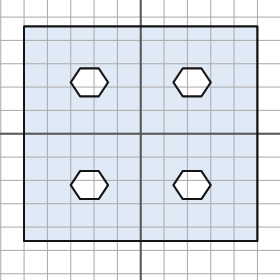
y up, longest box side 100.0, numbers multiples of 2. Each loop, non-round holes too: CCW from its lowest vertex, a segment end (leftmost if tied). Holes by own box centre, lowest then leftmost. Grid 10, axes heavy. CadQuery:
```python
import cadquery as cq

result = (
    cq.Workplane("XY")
    .moveTo(-50.0, -46.0)
    .lineTo(50.0, -46.0)
    .lineTo(50.0, 46.0)
    .lineTo(-50.0, 46.0)
    .close()
    .moveTo(-26.0, -28.0)
    .lineTo(-18.0, -28.0)
    .lineTo(-14.0, -22.0)
    .lineTo(-18.0, -16.0)
    .lineTo(-26.0, -16.0)
    .lineTo(-30.0, -22.0)
    .close()
    .moveTo(18.0, -28.0)
    .lineTo(26.0, -28.0)
    .lineTo(30.0, -22.0)
    .lineTo(26.0, -16.0)
    .lineTo(18.0, -16.0)
    .lineTo(14.0, -22.0)
    .close()
    .moveTo(-26.0, 16.0)
    .lineTo(-18.0, 16.0)
    .lineTo(-14.0, 22.0)
    .lineTo(-18.0, 28.0)
    .lineTo(-26.0, 28.0)
    .lineTo(-30.0, 22.0)
    .close()
    .moveTo(18.0, 16.0)
    .lineTo(26.0, 16.0)
    .lineTo(30.0, 22.0)
    .lineTo(26.0, 28.0)
    .lineTo(18.0, 28.0)
    .lineTo(14.0, 22.0)
    .close()
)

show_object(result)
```